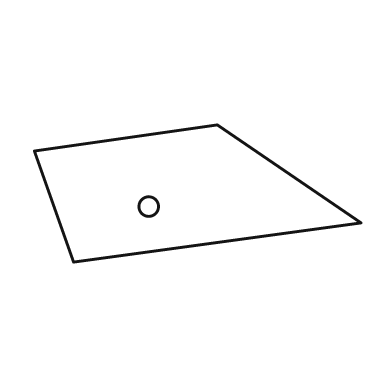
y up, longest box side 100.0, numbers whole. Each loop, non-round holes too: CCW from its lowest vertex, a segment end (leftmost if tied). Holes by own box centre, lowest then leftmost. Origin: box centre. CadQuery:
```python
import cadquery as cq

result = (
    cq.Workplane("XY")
    .moveTo(-38.0, -21.0)
    .lineTo(50.0, -9.0)
    .lineTo(6.0, 21.0)
    .lineTo(-50.0, 13.0)
    .close()
    .moveTo(-15.0, -4.0)
    .circle(3.0)
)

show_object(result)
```